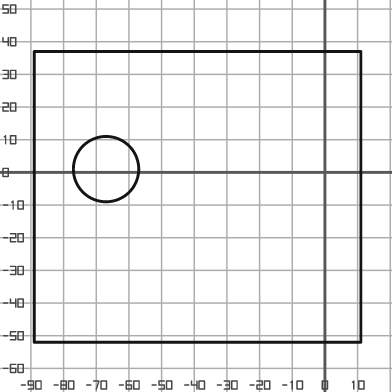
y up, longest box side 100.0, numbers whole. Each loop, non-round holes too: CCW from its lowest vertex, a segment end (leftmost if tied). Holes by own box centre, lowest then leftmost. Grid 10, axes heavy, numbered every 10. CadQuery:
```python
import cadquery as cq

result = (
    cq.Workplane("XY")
    .moveTo(-89.0, -52.0)
    .lineTo(11.0, -52.0)
    .lineTo(11.0, 37.0)
    .lineTo(-89.0, 37.0)
    .close()
    .moveTo(-67.0, 1.0)
    .circle(10.0)
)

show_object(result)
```